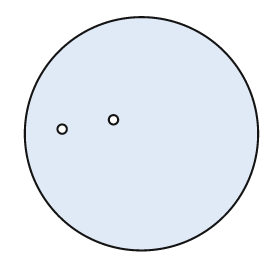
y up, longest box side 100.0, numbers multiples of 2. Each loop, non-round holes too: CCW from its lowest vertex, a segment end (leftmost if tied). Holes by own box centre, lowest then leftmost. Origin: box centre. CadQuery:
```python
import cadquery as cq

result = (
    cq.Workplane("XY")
    .moveTo(0.0, 0.0)
    .circle(50.0)
    .moveTo(-34.0, 2.0)
    .circle(2.0)
    .moveTo(-12.0, 6.0)
    .circle(2.0)
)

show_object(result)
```